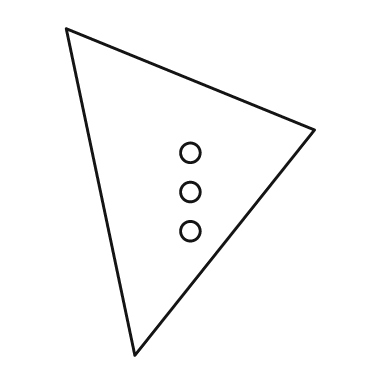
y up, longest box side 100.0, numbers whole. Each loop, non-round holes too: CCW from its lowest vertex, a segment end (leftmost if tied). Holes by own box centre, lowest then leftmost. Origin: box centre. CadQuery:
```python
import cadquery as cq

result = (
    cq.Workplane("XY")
    .moveTo(-17.0, -50.0)
    .lineTo(38.0, 19.0)
    .lineTo(-38.0, 50.0)
    .close()
    .moveTo(0.0, -12.0)
    .circle(3.0)
    .moveTo(0.0, 0.0)
    .circle(3.0)
    .moveTo(0.0, 12.0)
    .circle(3.0)
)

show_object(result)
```